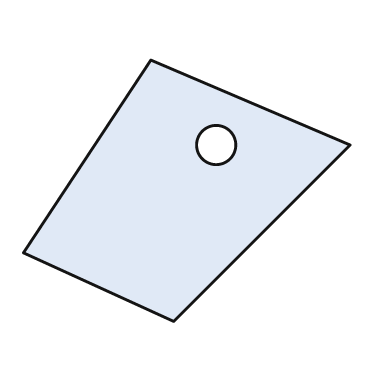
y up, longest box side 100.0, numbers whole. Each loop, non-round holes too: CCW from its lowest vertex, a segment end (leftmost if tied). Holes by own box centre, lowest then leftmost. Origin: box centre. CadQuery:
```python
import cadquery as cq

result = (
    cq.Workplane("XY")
    .moveTo(-4.0, -40.0)
    .lineTo(50.0, 14.0)
    .lineTo(-11.0, 40.0)
    .lineTo(-50.0, -19.0)
    .close()
    .moveTo(9.0, 14.0)
    .circle(6.0)
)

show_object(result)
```